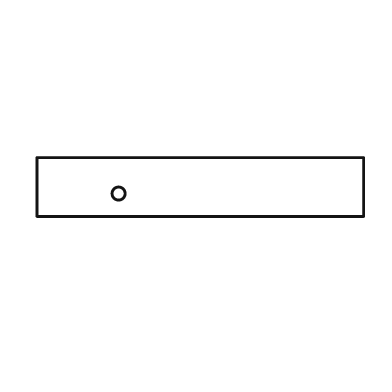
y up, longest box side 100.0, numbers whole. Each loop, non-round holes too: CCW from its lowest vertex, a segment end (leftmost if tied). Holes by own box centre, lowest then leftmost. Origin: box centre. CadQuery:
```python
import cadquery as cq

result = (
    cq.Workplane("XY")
    .moveTo(-50.0, -9.0)
    .lineTo(50.0, -9.0)
    .lineTo(50.0, 9.0)
    .lineTo(-50.0, 9.0)
    .close()
    .moveTo(-25.0, -2.0)
    .circle(2.0)
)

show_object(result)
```